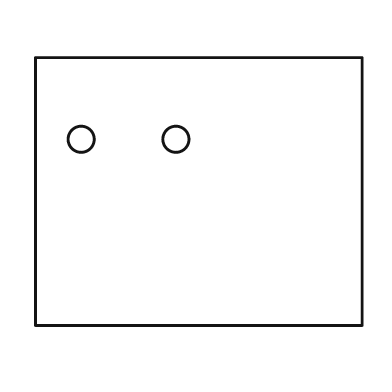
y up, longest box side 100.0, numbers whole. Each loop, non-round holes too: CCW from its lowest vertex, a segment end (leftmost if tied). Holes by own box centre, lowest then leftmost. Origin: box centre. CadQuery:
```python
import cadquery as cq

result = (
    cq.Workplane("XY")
    .moveTo(-50.0, -41.0)
    .lineTo(50.0, -41.0)
    .lineTo(50.0, 41.0)
    .lineTo(-50.0, 41.0)
    .close()
    .moveTo(-36.0, 16.0)
    .circle(4.0)
    .moveTo(-7.0, 16.0)
    .circle(4.0)
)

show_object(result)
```